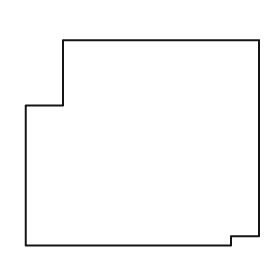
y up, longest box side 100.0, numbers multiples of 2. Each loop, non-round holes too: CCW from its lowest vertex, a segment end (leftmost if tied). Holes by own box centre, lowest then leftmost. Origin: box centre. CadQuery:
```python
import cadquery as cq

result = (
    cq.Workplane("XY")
    .moveTo(-50.0, -44.0)
    .lineTo(38.0, -44.0)
    .lineTo(38.0, -40.0)
    .lineTo(50.0, -40.0)
    .lineTo(50.0, 44.0)
    .lineTo(-34.0, 44.0)
    .lineTo(-34.0, 16.0)
    .lineTo(-50.0, 16.0)
    .close()
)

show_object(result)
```